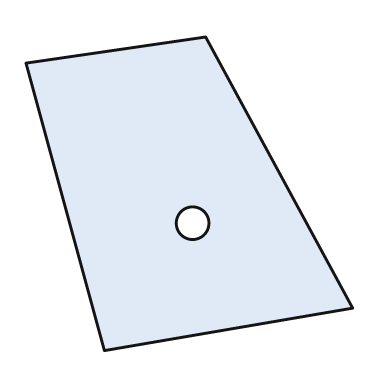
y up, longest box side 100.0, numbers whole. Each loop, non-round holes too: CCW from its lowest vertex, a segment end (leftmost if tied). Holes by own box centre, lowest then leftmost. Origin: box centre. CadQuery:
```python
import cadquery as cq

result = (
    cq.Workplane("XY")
    .moveTo(-26.0, -48.0)
    .lineTo(50.0, -35.0)
    .lineTo(5.0, 48.0)
    .lineTo(-50.0, 40.0)
    .close()
    .moveTo(1.0, -9.0)
    .circle(5.0)
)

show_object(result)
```